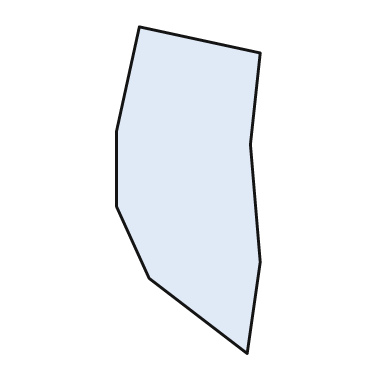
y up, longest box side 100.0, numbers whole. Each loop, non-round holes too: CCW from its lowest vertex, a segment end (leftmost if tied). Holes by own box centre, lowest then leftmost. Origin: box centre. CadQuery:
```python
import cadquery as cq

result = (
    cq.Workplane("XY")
    .moveTo(18.0, -50.0)
    .lineTo(22.0, -22.0)
    .lineTo(19.0, 14.0)
    .lineTo(22.0, 42.0)
    .lineTo(-15.0, 50.0)
    .lineTo(-22.0, 18.0)
    .lineTo(-22.0, -5.0)
    .lineTo(-12.0, -27.0)
    .close()
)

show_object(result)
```